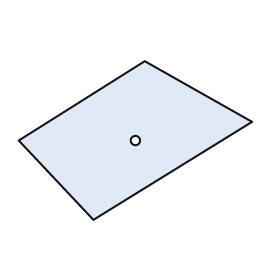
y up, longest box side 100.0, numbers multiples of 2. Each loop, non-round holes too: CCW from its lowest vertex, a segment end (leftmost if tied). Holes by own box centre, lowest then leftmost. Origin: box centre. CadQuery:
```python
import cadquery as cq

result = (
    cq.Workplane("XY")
    .moveTo(-18.0, -34.0)
    .lineTo(50.0, 8.0)
    .lineTo(4.0, 34.0)
    .lineTo(-50.0, 0.0)
    .close()
    .moveTo(0.0, 0.0)
    .circle(2.0)
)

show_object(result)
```